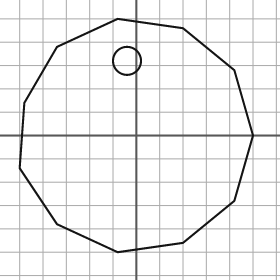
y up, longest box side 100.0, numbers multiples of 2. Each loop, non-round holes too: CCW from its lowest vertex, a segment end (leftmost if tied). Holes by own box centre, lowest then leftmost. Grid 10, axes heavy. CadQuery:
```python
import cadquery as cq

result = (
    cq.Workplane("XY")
    .moveTo(-8.0, -50.0)
    .lineTo(20.0, -46.0)
    .lineTo(42.0, -28.0)
    .lineTo(50.0, 0.0)
    .lineTo(42.0, 28.0)
    .lineTo(20.0, 46.0)
    .lineTo(-8.0, 50.0)
    .lineTo(-34.0, 38.0)
    .lineTo(-48.0, 14.0)
    .lineTo(-50.0, -14.0)
    .lineTo(-34.0, -38.0)
    .close()
    .moveTo(-4.0, 32.0)
    .circle(6.0)
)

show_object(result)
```